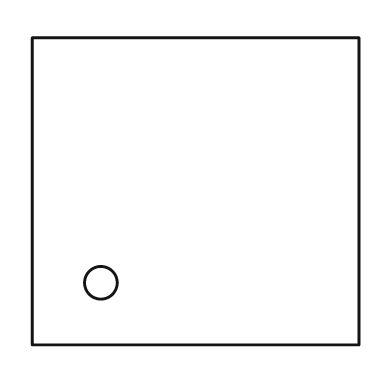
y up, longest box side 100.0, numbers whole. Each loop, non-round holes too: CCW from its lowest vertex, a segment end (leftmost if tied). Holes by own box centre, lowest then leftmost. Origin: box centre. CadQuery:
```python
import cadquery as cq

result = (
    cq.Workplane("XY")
    .moveTo(-50.0, -47.0)
    .lineTo(50.0, -47.0)
    .lineTo(50.0, 47.0)
    .lineTo(-50.0, 47.0)
    .close()
    .moveTo(-29.0, -28.0)
    .circle(5.0)
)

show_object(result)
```